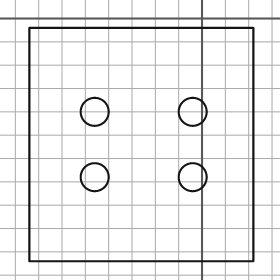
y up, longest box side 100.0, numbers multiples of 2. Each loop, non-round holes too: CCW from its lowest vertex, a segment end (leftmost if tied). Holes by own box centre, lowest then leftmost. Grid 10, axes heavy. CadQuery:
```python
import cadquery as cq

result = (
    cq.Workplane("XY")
    .moveTo(-74.0, -104.0)
    .lineTo(22.0, -104.0)
    .lineTo(22.0, -4.0)
    .lineTo(-74.0, -4.0)
    .close()
    .moveTo(-46.0, -68.0)
    .circle(6.0)
    .moveTo(-4.0, -68.0)
    .circle(6.0)
    .moveTo(-46.0, -40.0)
    .circle(6.0)
    .moveTo(-4.0, -40.0)
    .circle(6.0)
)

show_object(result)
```